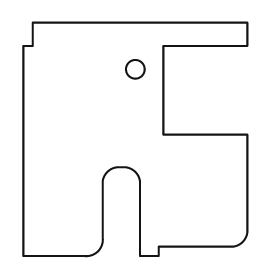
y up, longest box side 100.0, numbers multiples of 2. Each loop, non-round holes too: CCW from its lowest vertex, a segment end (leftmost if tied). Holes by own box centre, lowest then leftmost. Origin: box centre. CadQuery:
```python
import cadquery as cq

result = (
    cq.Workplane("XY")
    .moveTo(-48.0, -50.0)
    .lineTo(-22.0, -50.0)
    .threePointArc((-16.0, -48.0), (-14.0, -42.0))
    .lineTo(-14.0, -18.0)
    .threePointArc((-12.0, -14.0), (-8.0, -12.0))
    .lineTo(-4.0, -12.0)
    .threePointArc((0.0, -14.0), (2.0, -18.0))
    .lineTo(2.0, -50.0)
    .lineTo(10.0, -50.0)
    .lineTo(10.0, -46.0)
    .lineTo(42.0, -46.0)
    .threePointArc((46.0, -44.0), (48.0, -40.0))
    .lineTo(48.0, 2.0)
    .lineTo(12.0, 2.0)
    .lineTo(12.0, 40.0)
    .lineTo(48.0, 40.0)
    .lineTo(48.0, 50.0)
    .lineTo(-44.0, 50.0)
    .lineTo(-44.0, 40.0)
    .lineTo(-48.0, 40.0)
    .close()
    .moveTo(0.0, 30.0)
    .circle(4.0)
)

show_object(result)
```